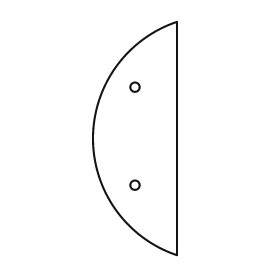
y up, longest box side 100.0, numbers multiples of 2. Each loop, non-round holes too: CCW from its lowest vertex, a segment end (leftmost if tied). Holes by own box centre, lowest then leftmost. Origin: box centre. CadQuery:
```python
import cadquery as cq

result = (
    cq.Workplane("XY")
    .moveTo(18.0, -50.0)
    .lineTo(18.0, 50.0)
    .threePointArc((-18.0, 0.0), (18.0, -50.0))
    .close()
    .moveTo(0.0, -20.0)
    .circle(2.0)
    .moveTo(0.0, 22.0)
    .circle(2.0)
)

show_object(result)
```